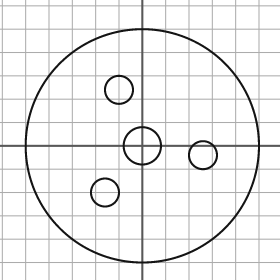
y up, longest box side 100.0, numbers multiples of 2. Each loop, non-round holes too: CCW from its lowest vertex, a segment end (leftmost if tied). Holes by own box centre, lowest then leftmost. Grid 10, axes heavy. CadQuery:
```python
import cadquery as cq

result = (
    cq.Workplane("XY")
    .moveTo(0.0, 0.0)
    .circle(50.0)
    .moveTo(-16.0, -20.0)
    .circle(6.0)
    .moveTo(26.0, -4.0)
    .circle(6.0)
    .moveTo(0.0, 0.0)
    .circle(8.0)
    .moveTo(-10.0, 24.0)
    .circle(6.0)
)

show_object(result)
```